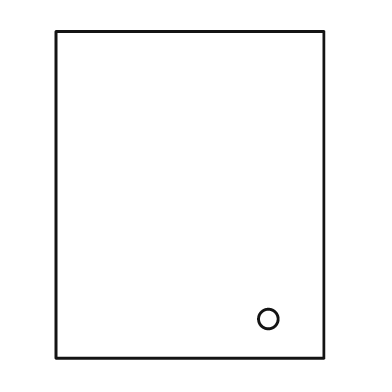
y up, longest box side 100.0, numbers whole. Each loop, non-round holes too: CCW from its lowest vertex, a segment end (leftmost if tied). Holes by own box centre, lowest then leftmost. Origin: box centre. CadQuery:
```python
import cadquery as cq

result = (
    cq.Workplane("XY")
    .moveTo(-41.0, -50.0)
    .lineTo(41.0, -50.0)
    .lineTo(41.0, 50.0)
    .lineTo(-41.0, 50.0)
    .close()
    .moveTo(24.0, -38.0)
    .circle(3.0)
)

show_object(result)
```